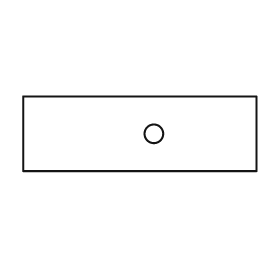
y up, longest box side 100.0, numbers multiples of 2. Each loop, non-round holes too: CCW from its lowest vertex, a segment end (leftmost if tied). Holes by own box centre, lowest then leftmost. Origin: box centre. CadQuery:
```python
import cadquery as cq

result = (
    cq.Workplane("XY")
    .moveTo(-50.0, -16.0)
    .lineTo(50.0, -16.0)
    .lineTo(50.0, 16.0)
    .lineTo(-50.0, 16.0)
    .close()
    .moveTo(6.0, 0.0)
    .circle(4.0)
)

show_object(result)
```